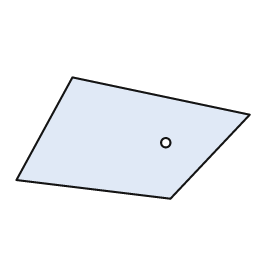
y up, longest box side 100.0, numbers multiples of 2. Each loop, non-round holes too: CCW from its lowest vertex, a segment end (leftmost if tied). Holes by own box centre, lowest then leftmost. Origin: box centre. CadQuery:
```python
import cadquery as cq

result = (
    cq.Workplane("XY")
    .moveTo(16.0, -26.0)
    .lineTo(50.0, 10.0)
    .lineTo(-26.0, 26.0)
    .lineTo(-50.0, -18.0)
    .close()
    .moveTo(14.0, -2.0)
    .circle(2.0)
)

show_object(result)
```